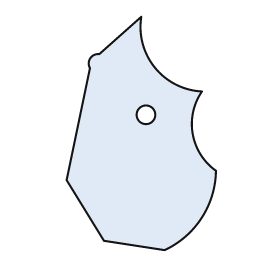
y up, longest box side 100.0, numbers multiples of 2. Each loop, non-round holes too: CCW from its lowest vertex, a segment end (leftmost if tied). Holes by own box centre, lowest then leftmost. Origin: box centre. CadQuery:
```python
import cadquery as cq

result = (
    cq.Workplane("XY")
    .moveTo(10.0, -50.0)
    .threePointArc((26.0, -36.0), (32.0, -16.0))
    .threePointArc((22.0, 0.0), (26.0, 18.0))
    .threePointArc((6.0, 28.0), (0.0, 50.0))
    .lineTo(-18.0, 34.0)
    .threePointArc((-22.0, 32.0), (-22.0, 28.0))
    .lineTo(-32.0, -20.0)
    .lineTo(-16.0, -46.0)
    .close()
    .moveTo(2.0, 8.0)
    .circle(4.0)
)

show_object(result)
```